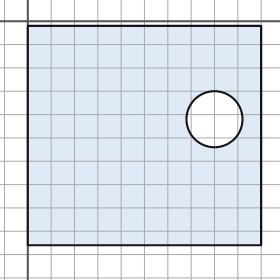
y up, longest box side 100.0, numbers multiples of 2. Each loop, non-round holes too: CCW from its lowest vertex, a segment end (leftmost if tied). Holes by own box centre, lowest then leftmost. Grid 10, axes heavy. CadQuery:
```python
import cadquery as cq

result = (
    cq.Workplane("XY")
    .moveTo(0.0, -96.0)
    .lineTo(100.0, -96.0)
    .lineTo(100.0, -2.0)
    .lineTo(0.0, -2.0)
    .close()
    .moveTo(80.0, -42.0)
    .circle(12.0)
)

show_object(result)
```